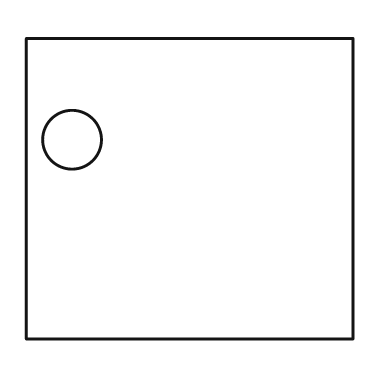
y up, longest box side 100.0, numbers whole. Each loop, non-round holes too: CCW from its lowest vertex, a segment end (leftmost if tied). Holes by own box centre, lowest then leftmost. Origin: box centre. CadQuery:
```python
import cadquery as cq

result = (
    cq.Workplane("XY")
    .moveTo(-50.0, -46.0)
    .lineTo(50.0, -46.0)
    .lineTo(50.0, 46.0)
    .lineTo(-50.0, 46.0)
    .close()
    .moveTo(-36.0, 15.0)
    .circle(9.0)
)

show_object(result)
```